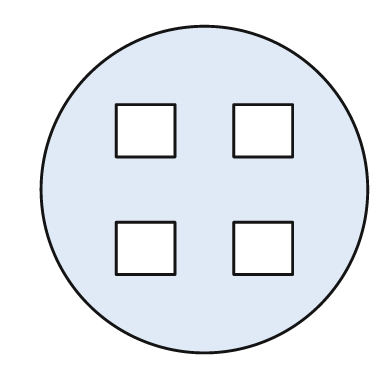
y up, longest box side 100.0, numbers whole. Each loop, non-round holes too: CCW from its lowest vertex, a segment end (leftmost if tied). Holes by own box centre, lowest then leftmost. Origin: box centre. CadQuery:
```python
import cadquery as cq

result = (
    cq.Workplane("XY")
    .moveTo(0.0, 0.0)
    .circle(50.0)
    .moveTo(-27.0, -26.0)
    .lineTo(-9.0, -26.0)
    .lineTo(-9.0, -10.0)
    .lineTo(-27.0, -10.0)
    .close()
    .moveTo(9.0, -26.0)
    .lineTo(27.0, -26.0)
    .lineTo(27.0, -10.0)
    .lineTo(9.0, -10.0)
    .close()
    .moveTo(-27.0, 10.0)
    .lineTo(-9.0, 10.0)
    .lineTo(-9.0, 26.0)
    .lineTo(-27.0, 26.0)
    .close()
    .moveTo(9.0, 10.0)
    .lineTo(27.0, 10.0)
    .lineTo(27.0, 26.0)
    .lineTo(9.0, 26.0)
    .close()
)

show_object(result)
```